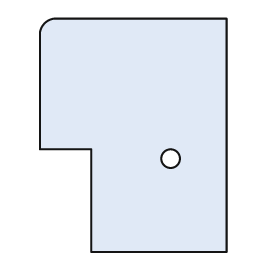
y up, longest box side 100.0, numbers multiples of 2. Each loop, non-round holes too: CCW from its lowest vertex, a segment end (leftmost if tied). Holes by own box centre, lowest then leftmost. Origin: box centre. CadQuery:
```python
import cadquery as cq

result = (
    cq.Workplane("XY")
    .moveTo(-18.0, -50.0)
    .lineTo(40.0, -50.0)
    .lineTo(40.0, 50.0)
    .lineTo(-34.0, 50.0)
    .threePointArc((-38.0, 48.0), (-40.0, 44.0))
    .lineTo(-40.0, -6.0)
    .lineTo(-18.0, -6.0)
    .close()
    .moveTo(16.0, -10.0)
    .circle(4.0)
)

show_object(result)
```